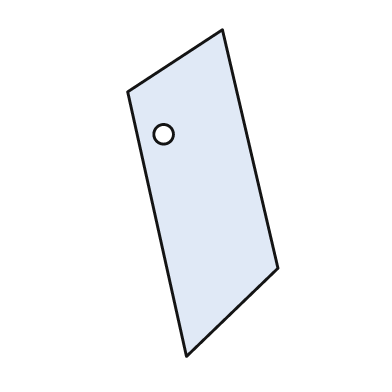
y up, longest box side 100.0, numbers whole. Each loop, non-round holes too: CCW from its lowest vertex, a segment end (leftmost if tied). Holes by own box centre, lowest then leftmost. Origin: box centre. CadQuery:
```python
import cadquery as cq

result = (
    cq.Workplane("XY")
    .moveTo(-5.0, -50.0)
    .lineTo(23.0, -23.0)
    .lineTo(6.0, 50.0)
    .lineTo(-23.0, 31.0)
    .close()
    .moveTo(-12.0, 18.0)
    .circle(3.0)
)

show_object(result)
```